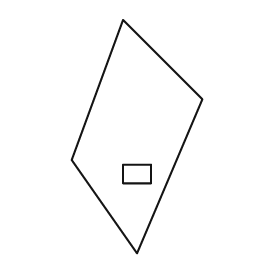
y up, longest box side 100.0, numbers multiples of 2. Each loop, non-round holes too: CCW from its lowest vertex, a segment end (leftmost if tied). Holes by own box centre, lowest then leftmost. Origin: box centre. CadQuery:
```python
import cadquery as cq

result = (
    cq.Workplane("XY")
    .moveTo(0.0, -50.0)
    .lineTo(28.0, 16.0)
    .lineTo(-6.0, 50.0)
    .lineTo(-28.0, -10.0)
    .close()
    .moveTo(-6.0, -20.0)
    .lineTo(6.0, -20.0)
    .lineTo(6.0, -12.0)
    .lineTo(-6.0, -12.0)
    .close()
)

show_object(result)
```